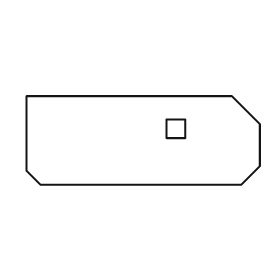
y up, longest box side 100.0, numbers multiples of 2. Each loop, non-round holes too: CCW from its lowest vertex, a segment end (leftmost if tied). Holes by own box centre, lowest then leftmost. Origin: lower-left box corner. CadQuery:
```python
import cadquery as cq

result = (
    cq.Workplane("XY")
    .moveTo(6.0, 0.0)
    .lineTo(92.0, 0.0)
    .lineTo(100.0, 8.0)
    .lineTo(100.0, 26.0)
    .lineTo(88.0, 38.0)
    .lineTo(0.0, 38.0)
    .lineTo(0.0, 6.0)
    .close()
    .moveTo(60.0, 20.0)
    .lineTo(68.0, 20.0)
    .lineTo(68.0, 28.0)
    .lineTo(60.0, 28.0)
    .close()
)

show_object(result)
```